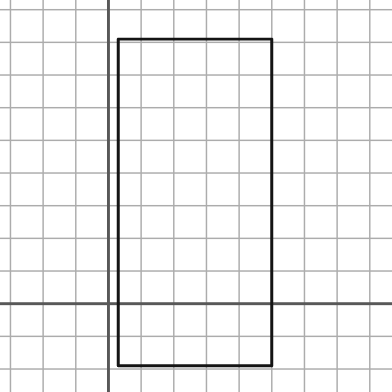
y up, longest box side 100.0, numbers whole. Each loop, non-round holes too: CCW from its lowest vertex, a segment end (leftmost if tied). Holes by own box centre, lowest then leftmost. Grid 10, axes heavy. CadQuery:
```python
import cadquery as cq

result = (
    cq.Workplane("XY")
    .moveTo(3.0, -19.0)
    .lineTo(50.0, -19.0)
    .lineTo(50.0, 81.0)
    .lineTo(3.0, 81.0)
    .close()
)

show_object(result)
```